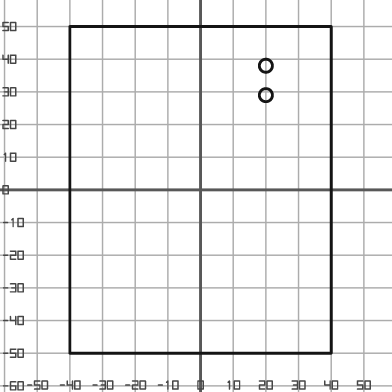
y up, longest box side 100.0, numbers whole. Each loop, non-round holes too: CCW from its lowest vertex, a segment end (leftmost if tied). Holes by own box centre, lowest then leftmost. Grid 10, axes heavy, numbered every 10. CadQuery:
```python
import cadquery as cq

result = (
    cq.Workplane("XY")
    .moveTo(-40.0, -50.0)
    .lineTo(40.0, -50.0)
    .lineTo(40.0, 50.0)
    .lineTo(-40.0, 50.0)
    .close()
    .moveTo(20.0, 29.0)
    .circle(2.0)
    .moveTo(20.0, 38.0)
    .circle(2.0)
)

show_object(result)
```